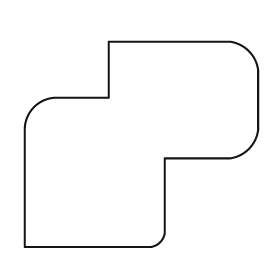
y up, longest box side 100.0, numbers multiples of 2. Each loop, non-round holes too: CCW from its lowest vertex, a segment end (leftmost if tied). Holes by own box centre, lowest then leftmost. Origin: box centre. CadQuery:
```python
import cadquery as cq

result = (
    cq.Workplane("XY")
    .moveTo(-50.0, -44.0)
    .lineTo(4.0, -44.0)
    .threePointArc((8.0, -42.0), (10.0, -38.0))
    .lineTo(10.0, -6.0)
    .lineTo(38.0, -6.0)
    .threePointArc((46.0, -2.0), (50.0, 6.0))
    .lineTo(50.0, 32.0)
    .threePointArc((46.0, 40.0), (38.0, 44.0))
    .lineTo(-14.0, 44.0)
    .lineTo(-14.0, 20.0)
    .lineTo(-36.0, 20.0)
    .threePointArc((-46.0, 16.0), (-50.0, 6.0))
    .close()
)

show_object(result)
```